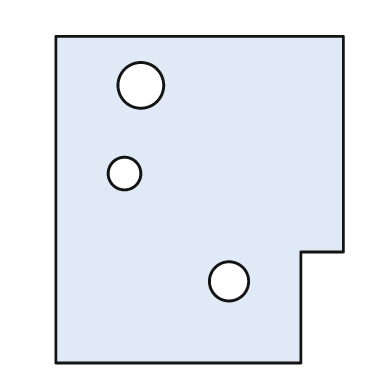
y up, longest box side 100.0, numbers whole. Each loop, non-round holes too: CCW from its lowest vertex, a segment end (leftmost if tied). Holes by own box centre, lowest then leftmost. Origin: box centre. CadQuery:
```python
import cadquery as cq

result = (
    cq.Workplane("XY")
    .moveTo(-44.0, -50.0)
    .lineTo(31.0, -50.0)
    .lineTo(31.0, -16.0)
    .lineTo(44.0, -16.0)
    .lineTo(44.0, 50.0)
    .lineTo(-44.0, 50.0)
    .close()
    .moveTo(9.0, -25.0)
    .circle(6.0)
    .moveTo(-23.0, 8.0)
    .circle(5.0)
    .moveTo(-18.0, 35.0)
    .circle(7.0)
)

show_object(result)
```